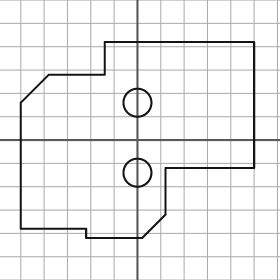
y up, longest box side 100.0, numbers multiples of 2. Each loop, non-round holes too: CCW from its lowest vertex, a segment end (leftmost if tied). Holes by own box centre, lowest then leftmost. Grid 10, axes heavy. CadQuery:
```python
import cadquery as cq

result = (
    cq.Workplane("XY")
    .moveTo(-22.0, -42.0)
    .lineTo(2.0, -42.0)
    .lineTo(12.0, -32.0)
    .lineTo(12.0, -12.0)
    .lineTo(50.0, -12.0)
    .lineTo(50.0, 42.0)
    .lineTo(-14.0, 42.0)
    .lineTo(-14.0, 28.0)
    .lineTo(-38.0, 28.0)
    .lineTo(-50.0, 16.0)
    .lineTo(-50.0, -38.0)
    .lineTo(-22.0, -38.0)
    .close()
    .moveTo(0.0, -14.0)
    .circle(6.0)
    .moveTo(0.0, 16.0)
    .circle(6.0)
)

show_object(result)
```